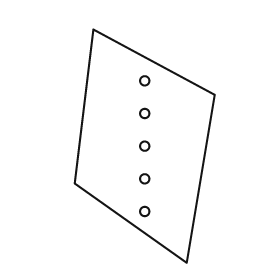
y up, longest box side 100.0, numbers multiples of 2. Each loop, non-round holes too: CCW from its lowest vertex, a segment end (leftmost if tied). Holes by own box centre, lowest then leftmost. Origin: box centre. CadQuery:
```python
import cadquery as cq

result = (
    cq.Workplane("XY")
    .moveTo(18.0, -50.0)
    .lineTo(30.0, 22.0)
    .lineTo(-22.0, 50.0)
    .lineTo(-30.0, -16.0)
    .close()
    .moveTo(0.0, -28.0)
    .circle(2.0)
    .moveTo(0.0, -14.0)
    .circle(2.0)
    .moveTo(0.0, 0.0)
    .circle(2.0)
    .moveTo(0.0, 14.0)
    .circle(2.0)
    .moveTo(0.0, 28.0)
    .circle(2.0)
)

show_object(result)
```